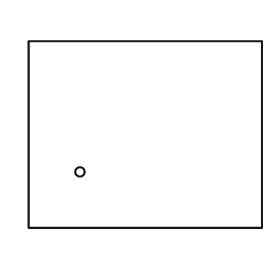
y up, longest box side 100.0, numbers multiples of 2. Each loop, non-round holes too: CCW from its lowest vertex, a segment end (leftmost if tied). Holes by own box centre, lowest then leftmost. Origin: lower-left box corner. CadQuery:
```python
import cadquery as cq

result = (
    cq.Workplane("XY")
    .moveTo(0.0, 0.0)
    .lineTo(100.0, 0.0)
    .lineTo(100.0, 80.0)
    .lineTo(0.0, 80.0)
    .close()
    .moveTo(22.0, 24.0)
    .circle(2.0)
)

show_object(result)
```